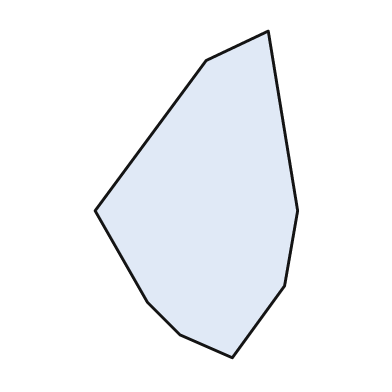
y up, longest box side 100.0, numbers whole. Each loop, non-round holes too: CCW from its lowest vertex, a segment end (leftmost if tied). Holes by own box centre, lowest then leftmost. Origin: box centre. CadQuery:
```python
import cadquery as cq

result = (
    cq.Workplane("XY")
    .moveTo(11.0, -50.0)
    .lineTo(27.0, -28.0)
    .lineTo(31.0, -5.0)
    .lineTo(22.0, 50.0)
    .lineTo(3.0, 41.0)
    .lineTo(-31.0, -5.0)
    .lineTo(-15.0, -33.0)
    .lineTo(-5.0, -43.0)
    .close()
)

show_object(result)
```